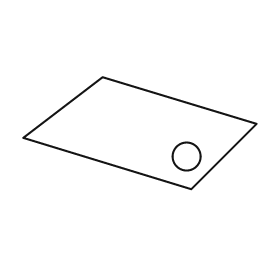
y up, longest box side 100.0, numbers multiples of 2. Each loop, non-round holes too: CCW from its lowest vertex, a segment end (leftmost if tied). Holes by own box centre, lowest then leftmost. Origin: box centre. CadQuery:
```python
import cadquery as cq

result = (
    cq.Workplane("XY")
    .moveTo(22.0, -24.0)
    .lineTo(50.0, 4.0)
    .lineTo(-16.0, 24.0)
    .lineTo(-50.0, -2.0)
    .close()
    .moveTo(20.0, -10.0)
    .circle(6.0)
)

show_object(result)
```